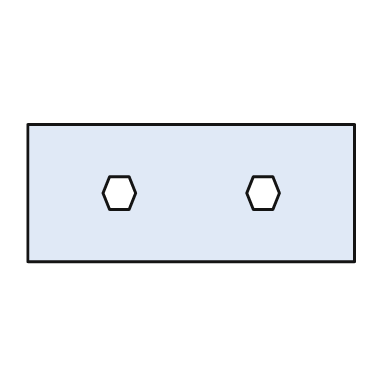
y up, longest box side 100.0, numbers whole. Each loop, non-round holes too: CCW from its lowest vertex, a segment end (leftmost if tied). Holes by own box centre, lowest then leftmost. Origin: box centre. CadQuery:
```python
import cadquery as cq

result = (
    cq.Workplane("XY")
    .moveTo(-50.0, -21.0)
    .lineTo(50.0, -21.0)
    .lineTo(50.0, 21.0)
    .lineTo(-50.0, 21.0)
    .close()
    .moveTo(-25.0, -5.0)
    .lineTo(-19.0, -5.0)
    .lineTo(-17.0, 0.0)
    .lineTo(-19.0, 5.0)
    .lineTo(-25.0, 5.0)
    .lineTo(-27.0, 0.0)
    .close()
    .moveTo(19.0, -5.0)
    .lineTo(25.0, -5.0)
    .lineTo(27.0, 0.0)
    .lineTo(25.0, 5.0)
    .lineTo(19.0, 5.0)
    .lineTo(17.0, 0.0)
    .close()
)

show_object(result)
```